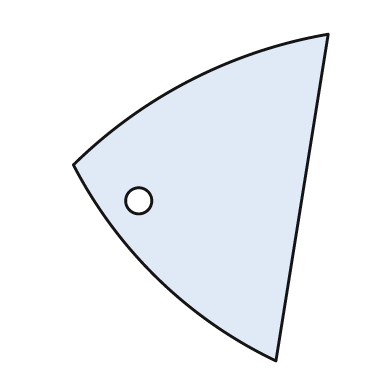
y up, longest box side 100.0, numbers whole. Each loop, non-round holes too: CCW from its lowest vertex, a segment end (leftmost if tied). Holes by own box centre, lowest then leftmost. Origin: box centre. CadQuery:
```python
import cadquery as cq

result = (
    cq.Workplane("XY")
    .moveTo(23.0, -50.0)
    .lineTo(39.0, 50.0)
    .threePointArc((-3.0, 36.0), (-39.0, 10.0))
    .threePointArc((-13.0, -25.0), (23.0, -50.0))
    .close()
    .moveTo(-19.0, -1.0)
    .circle(4.0)
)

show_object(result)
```